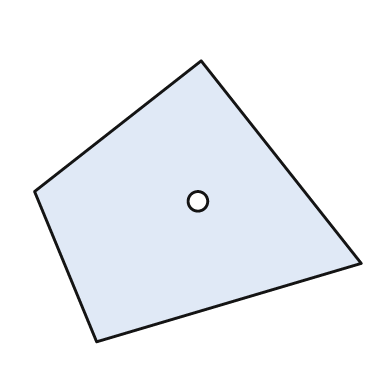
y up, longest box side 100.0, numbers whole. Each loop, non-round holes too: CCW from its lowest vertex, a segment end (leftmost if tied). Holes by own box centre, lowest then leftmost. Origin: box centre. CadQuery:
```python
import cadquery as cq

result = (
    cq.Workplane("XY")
    .moveTo(-31.0, -43.0)
    .lineTo(50.0, -19.0)
    .lineTo(1.0, 43.0)
    .lineTo(-50.0, 3.0)
    .close()
    .moveTo(0.0, 0.0)
    .circle(3.0)
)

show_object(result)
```